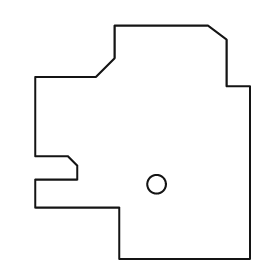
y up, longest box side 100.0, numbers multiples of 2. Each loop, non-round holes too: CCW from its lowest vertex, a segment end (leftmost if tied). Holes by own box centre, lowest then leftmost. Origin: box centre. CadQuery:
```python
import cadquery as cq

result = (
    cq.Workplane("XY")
    .moveTo(-10.0, -50.0)
    .lineTo(46.0, -50.0)
    .lineTo(46.0, 24.0)
    .lineTo(36.0, 24.0)
    .lineTo(36.0, 44.0)
    .lineTo(28.0, 50.0)
    .lineTo(-12.0, 50.0)
    .lineTo(-12.0, 36.0)
    .lineTo(-20.0, 28.0)
    .lineTo(-46.0, 28.0)
    .lineTo(-46.0, -6.0)
    .lineTo(-32.0, -6.0)
    .lineTo(-28.0, -10.0)
    .lineTo(-28.0, -16.0)
    .lineTo(-46.0, -16.0)
    .lineTo(-46.0, -28.0)
    .lineTo(-10.0, -28.0)
    .close()
    .moveTo(6.0, -18.0)
    .circle(4.0)
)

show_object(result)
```